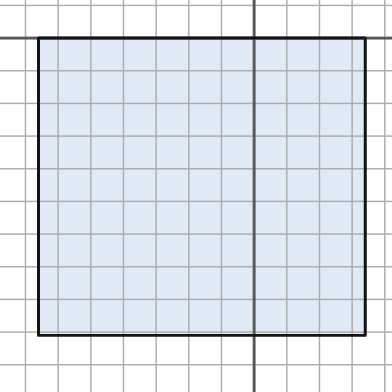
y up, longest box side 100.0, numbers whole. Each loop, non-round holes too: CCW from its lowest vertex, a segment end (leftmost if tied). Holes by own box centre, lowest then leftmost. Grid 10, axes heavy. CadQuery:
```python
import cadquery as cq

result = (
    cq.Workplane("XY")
    .moveTo(-66.0, -91.0)
    .lineTo(34.0, -91.0)
    .lineTo(34.0, 0.0)
    .lineTo(-66.0, 0.0)
    .close()
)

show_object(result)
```